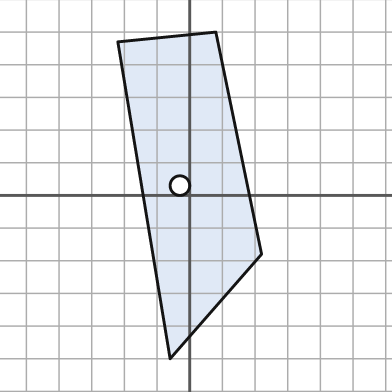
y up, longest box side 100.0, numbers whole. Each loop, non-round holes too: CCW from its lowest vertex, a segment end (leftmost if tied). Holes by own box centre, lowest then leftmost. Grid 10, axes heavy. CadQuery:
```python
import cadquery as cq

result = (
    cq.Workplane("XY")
    .moveTo(-6.0, -50.0)
    .lineTo(22.0, -18.0)
    .lineTo(8.0, 50.0)
    .lineTo(-22.0, 47.0)
    .close()
    .moveTo(-3.0, 3.0)
    .circle(3.0)
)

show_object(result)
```